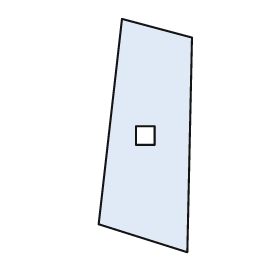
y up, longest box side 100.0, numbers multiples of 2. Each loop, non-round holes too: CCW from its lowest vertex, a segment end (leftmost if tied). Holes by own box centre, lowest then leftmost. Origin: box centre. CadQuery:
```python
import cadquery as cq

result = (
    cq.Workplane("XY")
    .moveTo(18.0, -50.0)
    .lineTo(20.0, 42.0)
    .lineTo(-10.0, 50.0)
    .lineTo(-20.0, -38.0)
    .close()
    .moveTo(-4.0, -4.0)
    .lineTo(4.0, -4.0)
    .lineTo(4.0, 4.0)
    .lineTo(-4.0, 4.0)
    .close()
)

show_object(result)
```